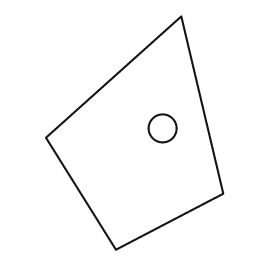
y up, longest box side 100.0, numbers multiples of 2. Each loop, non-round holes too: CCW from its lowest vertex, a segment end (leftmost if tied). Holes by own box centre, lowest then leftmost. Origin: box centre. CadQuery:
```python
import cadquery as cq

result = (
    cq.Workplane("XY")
    .moveTo(-8.0, -50.0)
    .lineTo(38.0, -26.0)
    .lineTo(20.0, 50.0)
    .lineTo(-38.0, -2.0)
    .close()
    .moveTo(12.0, 2.0)
    .circle(6.0)
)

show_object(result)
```